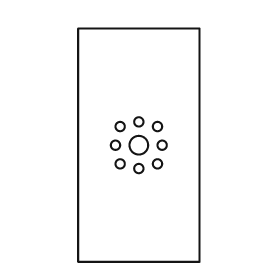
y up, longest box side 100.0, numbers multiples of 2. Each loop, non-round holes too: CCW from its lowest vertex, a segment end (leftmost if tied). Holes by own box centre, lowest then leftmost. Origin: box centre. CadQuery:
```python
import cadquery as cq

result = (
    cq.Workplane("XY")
    .moveTo(-26.0, -50.0)
    .lineTo(26.0, -50.0)
    .lineTo(26.0, 50.0)
    .lineTo(-26.0, 50.0)
    .close()
    .moveTo(0.0, -10.0)
    .circle(2.0)
    .moveTo(-8.0, -8.0)
    .circle(2.0)
    .moveTo(8.0, -8.0)
    .circle(2.0)
    .moveTo(-10.0, 0.0)
    .circle(2.0)
    .moveTo(0.0, 0.0)
    .circle(4.0)
    .moveTo(10.0, 0.0)
    .circle(2.0)
    .moveTo(-8.0, 8.0)
    .circle(2.0)
    .moveTo(8.0, 8.0)
    .circle(2.0)
    .moveTo(0.0, 10.0)
    .circle(2.0)
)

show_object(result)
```